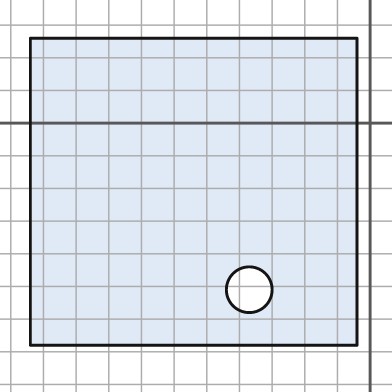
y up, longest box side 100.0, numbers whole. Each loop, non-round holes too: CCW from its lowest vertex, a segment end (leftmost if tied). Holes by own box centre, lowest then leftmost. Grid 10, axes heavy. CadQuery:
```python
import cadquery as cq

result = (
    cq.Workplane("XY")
    .moveTo(-104.0, -68.0)
    .lineTo(-4.0, -68.0)
    .lineTo(-4.0, 26.0)
    .lineTo(-104.0, 26.0)
    .close()
    .moveTo(-37.0, -51.0)
    .circle(7.0)
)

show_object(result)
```